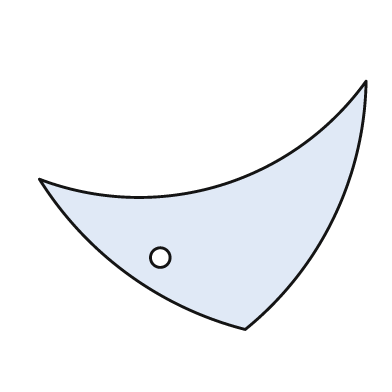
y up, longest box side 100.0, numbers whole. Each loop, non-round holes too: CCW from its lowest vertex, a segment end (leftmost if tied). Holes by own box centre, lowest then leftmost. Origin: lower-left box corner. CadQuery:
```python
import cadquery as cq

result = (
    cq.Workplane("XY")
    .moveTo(63.0, 0.0)
    .threePointArc((90.0, 34.0), (100.0, 76.0))
    .threePointArc((55.0, 44.0), (0.0, 46.0))
    .threePointArc((27.0, 17.0), (63.0, 0.0))
    .close()
    .moveTo(37.0, 22.0)
    .circle(3.0)
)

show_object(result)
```